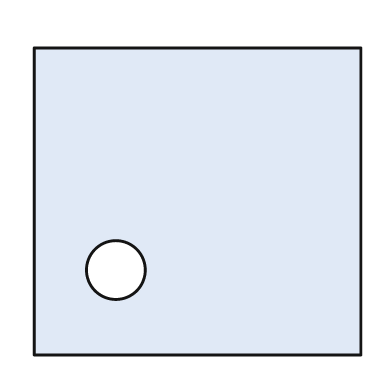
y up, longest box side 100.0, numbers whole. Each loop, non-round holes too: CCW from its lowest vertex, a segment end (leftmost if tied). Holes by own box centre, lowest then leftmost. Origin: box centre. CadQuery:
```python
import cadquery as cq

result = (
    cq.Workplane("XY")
    .moveTo(-50.0, -47.0)
    .lineTo(50.0, -47.0)
    .lineTo(50.0, 47.0)
    .lineTo(-50.0, 47.0)
    .close()
    .moveTo(-25.0, -21.0)
    .circle(9.0)
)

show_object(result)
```